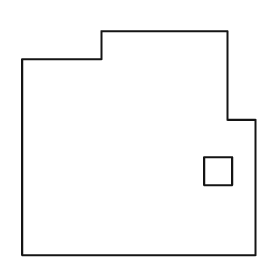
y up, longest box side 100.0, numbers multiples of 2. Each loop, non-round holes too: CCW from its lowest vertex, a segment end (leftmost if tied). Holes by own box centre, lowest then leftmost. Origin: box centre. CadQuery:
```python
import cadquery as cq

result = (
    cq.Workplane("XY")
    .moveTo(-50.0, -48.0)
    .lineTo(50.0, -48.0)
    .lineTo(50.0, 10.0)
    .lineTo(38.0, 10.0)
    .lineTo(38.0, 48.0)
    .lineTo(-16.0, 48.0)
    .lineTo(-16.0, 36.0)
    .lineTo(-50.0, 36.0)
    .close()
    .moveTo(28.0, -18.0)
    .lineTo(40.0, -18.0)
    .lineTo(40.0, -6.0)
    .lineTo(28.0, -6.0)
    .close()
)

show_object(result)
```